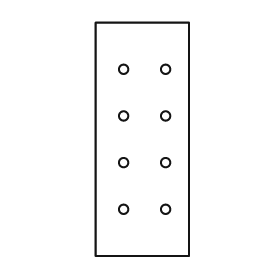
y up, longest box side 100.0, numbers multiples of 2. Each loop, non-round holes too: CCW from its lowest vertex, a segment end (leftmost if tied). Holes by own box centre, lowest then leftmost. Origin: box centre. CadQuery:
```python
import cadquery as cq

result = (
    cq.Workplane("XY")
    .moveTo(-20.0, -50.0)
    .lineTo(20.0, -50.0)
    .lineTo(20.0, 50.0)
    .lineTo(-20.0, 50.0)
    .close()
    .moveTo(-8.0, -30.0)
    .circle(2.0)
    .moveTo(10.0, -30.0)
    .circle(2.0)
    .moveTo(-8.0, -10.0)
    .circle(2.0)
    .moveTo(10.0, -10.0)
    .circle(2.0)
    .moveTo(-8.0, 10.0)
    .circle(2.0)
    .moveTo(10.0, 10.0)
    .circle(2.0)
    .moveTo(-8.0, 30.0)
    .circle(2.0)
    .moveTo(10.0, 30.0)
    .circle(2.0)
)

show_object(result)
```